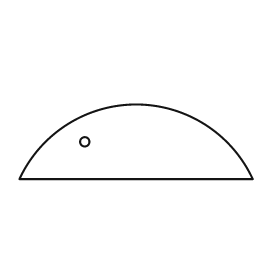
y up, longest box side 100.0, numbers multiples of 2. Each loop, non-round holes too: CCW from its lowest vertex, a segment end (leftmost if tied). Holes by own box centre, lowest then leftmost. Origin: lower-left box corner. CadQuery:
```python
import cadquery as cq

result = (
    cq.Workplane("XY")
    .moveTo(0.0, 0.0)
    .lineTo(100.0, 0.0)
    .threePointArc((50.0, 32.0), (0.0, 0.0))
    .close()
    .moveTo(28.0, 16.0)
    .circle(2.0)
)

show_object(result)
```